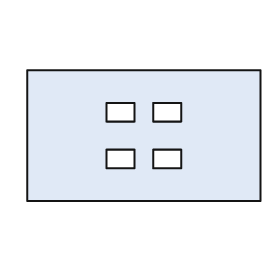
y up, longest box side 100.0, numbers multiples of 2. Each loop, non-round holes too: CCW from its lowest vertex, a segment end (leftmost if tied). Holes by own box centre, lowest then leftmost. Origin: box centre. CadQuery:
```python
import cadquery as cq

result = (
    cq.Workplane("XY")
    .moveTo(-50.0, -28.0)
    .lineTo(50.0, -28.0)
    .lineTo(50.0, 28.0)
    .lineTo(-50.0, 28.0)
    .close()
    .moveTo(-16.0, -14.0)
    .lineTo(-4.0, -14.0)
    .lineTo(-4.0, -6.0)
    .lineTo(-16.0, -6.0)
    .close()
    .moveTo(4.0, -14.0)
    .lineTo(16.0, -14.0)
    .lineTo(16.0, -6.0)
    .lineTo(4.0, -6.0)
    .close()
    .moveTo(-16.0, 6.0)
    .lineTo(-4.0, 6.0)
    .lineTo(-4.0, 14.0)
    .lineTo(-16.0, 14.0)
    .close()
    .moveTo(4.0, 6.0)
    .lineTo(16.0, 6.0)
    .lineTo(16.0, 14.0)
    .lineTo(4.0, 14.0)
    .close()
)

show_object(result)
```